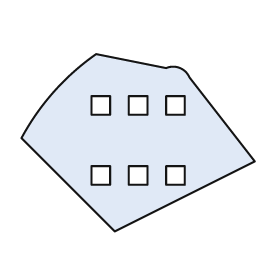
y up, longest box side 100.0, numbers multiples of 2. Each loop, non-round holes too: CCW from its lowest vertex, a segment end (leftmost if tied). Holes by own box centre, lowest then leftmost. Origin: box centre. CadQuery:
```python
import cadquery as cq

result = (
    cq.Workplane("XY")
    .moveTo(-10.0, -38.0)
    .lineTo(50.0, -8.0)
    .lineTo(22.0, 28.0)
    .threePointArc((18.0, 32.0), (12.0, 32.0))
    .lineTo(-18.0, 38.0)
    .threePointArc((-36.0, 22.0), (-50.0, 2.0))
    .close()
    .moveTo(-20.0, -18.0)
    .lineTo(-12.0, -18.0)
    .lineTo(-12.0, -10.0)
    .lineTo(-20.0, -10.0)
    .close()
    .moveTo(-4.0, -18.0)
    .lineTo(4.0, -18.0)
    .lineTo(4.0, -10.0)
    .lineTo(-4.0, -10.0)
    .close()
    .moveTo(12.0, -18.0)
    .lineTo(20.0, -18.0)
    .lineTo(20.0, -10.0)
    .lineTo(12.0, -10.0)
    .close()
    .moveTo(-20.0, 12.0)
    .lineTo(-12.0, 12.0)
    .lineTo(-12.0, 20.0)
    .lineTo(-20.0, 20.0)
    .close()
    .moveTo(-4.0, 12.0)
    .lineTo(4.0, 12.0)
    .lineTo(4.0, 20.0)
    .lineTo(-4.0, 20.0)
    .close()
    .moveTo(12.0, 12.0)
    .lineTo(20.0, 12.0)
    .lineTo(20.0, 20.0)
    .lineTo(12.0, 20.0)
    .close()
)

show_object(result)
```